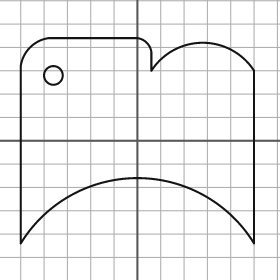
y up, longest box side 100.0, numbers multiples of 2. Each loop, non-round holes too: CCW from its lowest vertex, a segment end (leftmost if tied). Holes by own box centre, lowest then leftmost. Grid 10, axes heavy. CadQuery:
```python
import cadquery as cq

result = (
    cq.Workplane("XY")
    .moveTo(-50.0, -44.0)
    .threePointArc((0.0, -16.0), (50.0, -44.0))
    .lineTo(50.0, 30.0)
    .threePointArc((28.0, 42.0), (6.0, 30.0))
    .lineTo(6.0, 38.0)
    .threePointArc((4.0, 42.0), (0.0, 44.0))
    .lineTo(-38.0, 44.0)
    .threePointArc((-46.0, 40.0), (-50.0, 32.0))
    .close()
    .moveTo(-36.0, 28.0)
    .circle(4.0)
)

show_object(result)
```